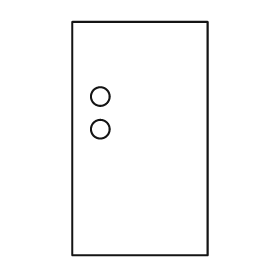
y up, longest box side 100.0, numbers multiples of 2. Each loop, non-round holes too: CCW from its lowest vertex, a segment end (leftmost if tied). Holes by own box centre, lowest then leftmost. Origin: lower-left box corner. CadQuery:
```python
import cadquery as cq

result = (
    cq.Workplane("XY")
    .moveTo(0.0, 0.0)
    .lineTo(58.0, 0.0)
    .lineTo(58.0, 100.0)
    .lineTo(0.0, 100.0)
    .close()
    .moveTo(12.0, 54.0)
    .circle(4.0)
    .moveTo(12.0, 68.0)
    .circle(4.0)
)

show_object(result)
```